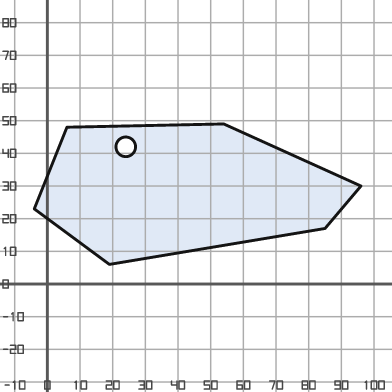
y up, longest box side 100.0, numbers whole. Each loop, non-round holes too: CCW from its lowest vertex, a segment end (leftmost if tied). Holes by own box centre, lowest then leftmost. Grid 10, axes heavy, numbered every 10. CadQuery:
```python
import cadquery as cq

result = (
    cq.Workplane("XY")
    .moveTo(19.0, 6.0)
    .lineTo(85.0, 17.0)
    .lineTo(96.0, 30.0)
    .lineTo(54.0, 49.0)
    .lineTo(6.0, 48.0)
    .lineTo(-4.0, 23.0)
    .close()
    .moveTo(24.0, 42.0)
    .circle(3.0)
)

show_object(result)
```